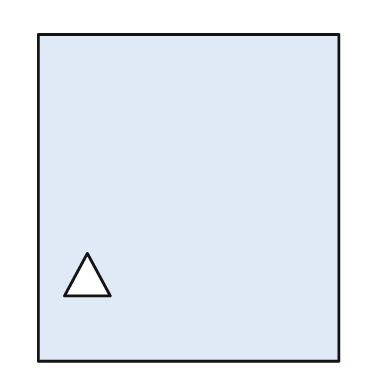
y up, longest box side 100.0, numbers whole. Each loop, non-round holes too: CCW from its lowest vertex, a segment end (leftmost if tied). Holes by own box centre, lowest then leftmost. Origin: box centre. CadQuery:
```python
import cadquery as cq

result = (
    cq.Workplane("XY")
    .moveTo(-46.0, -50.0)
    .lineTo(46.0, -50.0)
    .lineTo(46.0, 50.0)
    .lineTo(-46.0, 50.0)
    .close()
    .moveTo(-38.0, -30.0)
    .lineTo(-24.0, -30.0)
    .lineTo(-31.0, -17.0)
    .close()
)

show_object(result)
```